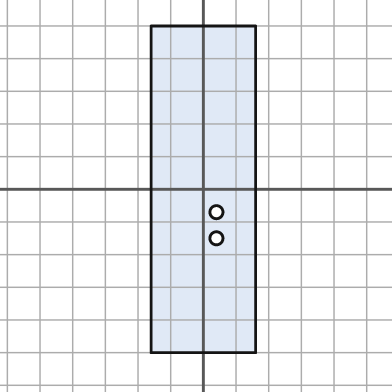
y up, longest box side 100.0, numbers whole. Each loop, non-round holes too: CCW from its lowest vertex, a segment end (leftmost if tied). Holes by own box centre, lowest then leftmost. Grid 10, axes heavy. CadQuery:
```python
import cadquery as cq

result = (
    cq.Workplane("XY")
    .moveTo(-16.0, -50.0)
    .lineTo(16.0, -50.0)
    .lineTo(16.0, 50.0)
    .lineTo(-16.0, 50.0)
    .close()
    .moveTo(4.0, -15.0)
    .circle(2.0)
    .moveTo(4.0, -7.0)
    .circle(2.0)
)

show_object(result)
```